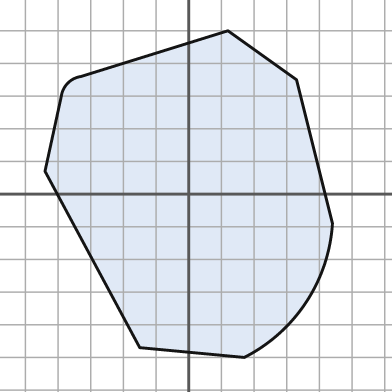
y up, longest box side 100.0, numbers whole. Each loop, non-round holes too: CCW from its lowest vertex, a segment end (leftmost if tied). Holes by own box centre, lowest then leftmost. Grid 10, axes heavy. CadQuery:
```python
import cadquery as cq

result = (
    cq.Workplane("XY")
    .moveTo(17.0, -50.0)
    .threePointArc((36.0, -33.0), (44.0, -9.0))
    .lineTo(33.0, 35.0)
    .lineTo(12.0, 50.0)
    .lineTo(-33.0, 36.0)
    .threePointArc((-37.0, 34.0), (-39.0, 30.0))
    .lineTo(-44.0, 7.0)
    .lineTo(-15.0, -47.0)
    .close()
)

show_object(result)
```